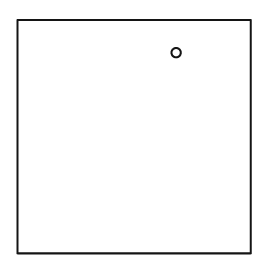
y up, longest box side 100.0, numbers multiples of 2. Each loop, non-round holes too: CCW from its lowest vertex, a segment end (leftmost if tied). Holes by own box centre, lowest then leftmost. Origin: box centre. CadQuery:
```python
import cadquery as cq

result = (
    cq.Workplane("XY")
    .moveTo(-50.0, -50.0)
    .lineTo(50.0, -50.0)
    .lineTo(50.0, 50.0)
    .lineTo(-50.0, 50.0)
    .close()
    .moveTo(18.0, 36.0)
    .circle(2.0)
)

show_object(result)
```